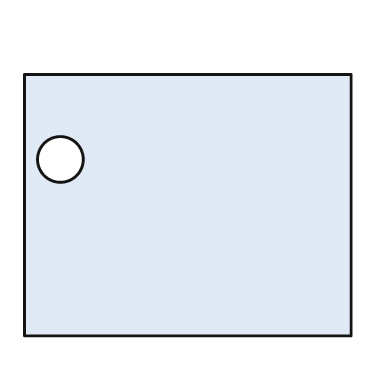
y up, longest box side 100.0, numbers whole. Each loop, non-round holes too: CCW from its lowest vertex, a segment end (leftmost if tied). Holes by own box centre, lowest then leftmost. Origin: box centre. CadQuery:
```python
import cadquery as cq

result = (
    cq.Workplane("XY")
    .moveTo(-50.0, -40.0)
    .lineTo(50.0, -40.0)
    .lineTo(50.0, 40.0)
    .lineTo(-50.0, 40.0)
    .close()
    .moveTo(-39.0, 14.0)
    .circle(7.0)
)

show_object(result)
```